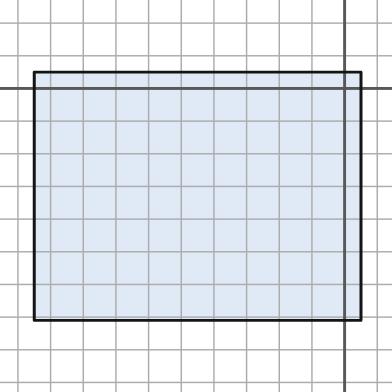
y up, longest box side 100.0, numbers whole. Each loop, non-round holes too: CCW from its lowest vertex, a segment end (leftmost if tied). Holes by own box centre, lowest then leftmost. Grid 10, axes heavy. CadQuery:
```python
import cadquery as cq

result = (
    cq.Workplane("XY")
    .moveTo(-95.0, -71.0)
    .lineTo(5.0, -71.0)
    .lineTo(5.0, 5.0)
    .lineTo(-95.0, 5.0)
    .close()
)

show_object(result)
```